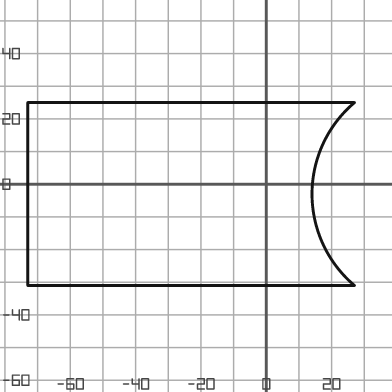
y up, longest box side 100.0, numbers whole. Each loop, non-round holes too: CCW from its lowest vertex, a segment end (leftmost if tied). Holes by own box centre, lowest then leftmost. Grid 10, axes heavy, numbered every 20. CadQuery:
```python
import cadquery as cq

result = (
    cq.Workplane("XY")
    .moveTo(-73.0, -31.0)
    .lineTo(27.0, -31.0)
    .threePointArc((14.0, -3.0), (27.0, 25.0))
    .lineTo(-73.0, 25.0)
    .close()
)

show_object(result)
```